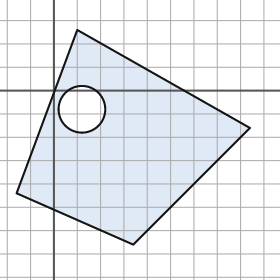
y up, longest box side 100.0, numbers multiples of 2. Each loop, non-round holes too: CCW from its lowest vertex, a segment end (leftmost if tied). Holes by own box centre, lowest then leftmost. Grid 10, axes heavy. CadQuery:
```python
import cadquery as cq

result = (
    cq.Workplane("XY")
    .moveTo(34.0, -66.0)
    .lineTo(84.0, -16.0)
    .lineTo(10.0, 26.0)
    .lineTo(-16.0, -44.0)
    .close()
    .moveTo(12.0, -8.0)
    .circle(10.0)
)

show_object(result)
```